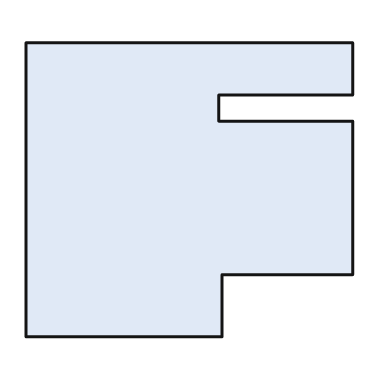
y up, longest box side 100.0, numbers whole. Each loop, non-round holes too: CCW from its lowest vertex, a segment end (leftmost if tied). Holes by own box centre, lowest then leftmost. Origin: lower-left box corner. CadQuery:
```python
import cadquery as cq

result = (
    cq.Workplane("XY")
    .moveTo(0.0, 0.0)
    .lineTo(60.0, 0.0)
    .lineTo(60.0, 19.0)
    .lineTo(100.0, 19.0)
    .lineTo(100.0, 66.0)
    .lineTo(59.0, 66.0)
    .lineTo(59.0, 74.0)
    .lineTo(100.0, 74.0)
    .lineTo(100.0, 90.0)
    .lineTo(0.0, 90.0)
    .close()
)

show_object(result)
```